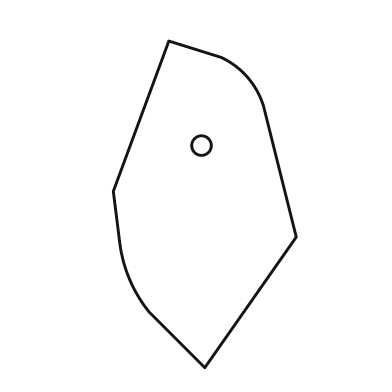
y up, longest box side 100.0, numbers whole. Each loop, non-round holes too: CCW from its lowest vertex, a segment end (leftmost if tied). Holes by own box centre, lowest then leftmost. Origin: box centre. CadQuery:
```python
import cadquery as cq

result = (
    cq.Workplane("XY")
    .moveTo(0.0, -50.0)
    .lineTo(28.0, -10.0)
    .lineTo(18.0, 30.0)
    .threePointArc((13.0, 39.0), (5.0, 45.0))
    .lineTo(-11.0, 50.0)
    .lineTo(-28.0, 4.0)
    .lineTo(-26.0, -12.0)
    .threePointArc((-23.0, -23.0), (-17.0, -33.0))
    .close()
    .moveTo(-1.0, 18.0)
    .circle(3.0)
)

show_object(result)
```